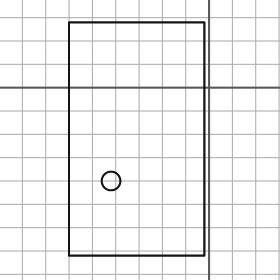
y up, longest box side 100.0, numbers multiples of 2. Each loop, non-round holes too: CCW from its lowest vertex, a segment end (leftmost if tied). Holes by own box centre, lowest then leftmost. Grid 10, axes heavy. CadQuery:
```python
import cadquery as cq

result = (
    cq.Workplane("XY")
    .moveTo(-60.0, -72.0)
    .lineTo(-2.0, -72.0)
    .lineTo(-2.0, 28.0)
    .lineTo(-60.0, 28.0)
    .close()
    .moveTo(-42.0, -40.0)
    .circle(4.0)
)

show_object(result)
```